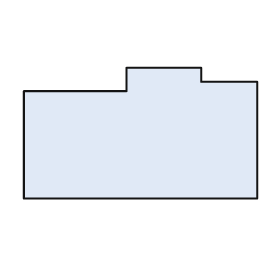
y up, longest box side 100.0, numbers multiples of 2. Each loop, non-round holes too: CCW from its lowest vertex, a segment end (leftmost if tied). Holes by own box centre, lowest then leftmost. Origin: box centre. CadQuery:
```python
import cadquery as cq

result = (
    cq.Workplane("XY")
    .moveTo(-50.0, -28.0)
    .lineTo(50.0, -28.0)
    .lineTo(50.0, 22.0)
    .lineTo(26.0, 22.0)
    .lineTo(26.0, 28.0)
    .lineTo(-6.0, 28.0)
    .lineTo(-6.0, 18.0)
    .lineTo(-50.0, 18.0)
    .close()
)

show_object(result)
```